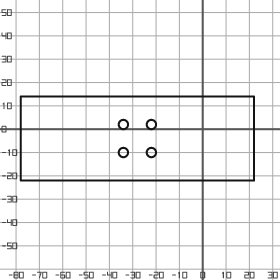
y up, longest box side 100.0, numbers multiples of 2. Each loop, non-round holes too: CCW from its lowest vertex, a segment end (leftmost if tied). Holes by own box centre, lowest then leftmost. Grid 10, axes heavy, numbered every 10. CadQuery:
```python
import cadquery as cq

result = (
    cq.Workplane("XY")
    .moveTo(-78.0, -22.0)
    .lineTo(22.0, -22.0)
    .lineTo(22.0, 14.0)
    .lineTo(-78.0, 14.0)
    .close()
    .moveTo(-34.0, -10.0)
    .circle(2.0)
    .moveTo(-22.0, -10.0)
    .circle(2.0)
    .moveTo(-34.0, 2.0)
    .circle(2.0)
    .moveTo(-22.0, 2.0)
    .circle(2.0)
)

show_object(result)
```